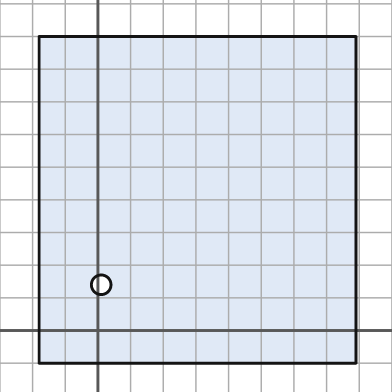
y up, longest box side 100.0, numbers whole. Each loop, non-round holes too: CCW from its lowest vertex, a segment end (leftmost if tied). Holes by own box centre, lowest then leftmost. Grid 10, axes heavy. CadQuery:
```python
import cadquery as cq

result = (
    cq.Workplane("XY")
    .moveTo(-18.0, -10.0)
    .lineTo(79.0, -10.0)
    .lineTo(79.0, 90.0)
    .lineTo(-18.0, 90.0)
    .close()
    .moveTo(1.0, 14.0)
    .circle(3.0)
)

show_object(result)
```